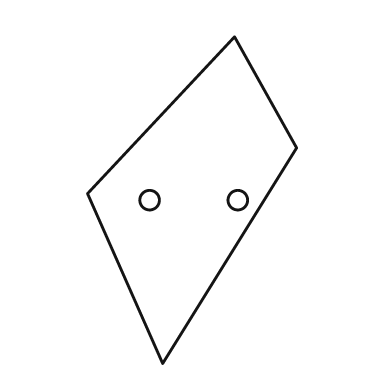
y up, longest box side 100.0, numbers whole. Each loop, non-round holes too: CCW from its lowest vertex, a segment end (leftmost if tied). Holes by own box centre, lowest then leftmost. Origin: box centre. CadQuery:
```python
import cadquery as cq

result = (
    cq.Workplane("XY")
    .moveTo(-9.0, -50.0)
    .lineTo(32.0, 16.0)
    .lineTo(13.0, 50.0)
    .lineTo(-32.0, 2.0)
    .close()
    .moveTo(-13.0, 0.0)
    .circle(3.0)
    .moveTo(14.0, 0.0)
    .circle(3.0)
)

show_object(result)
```